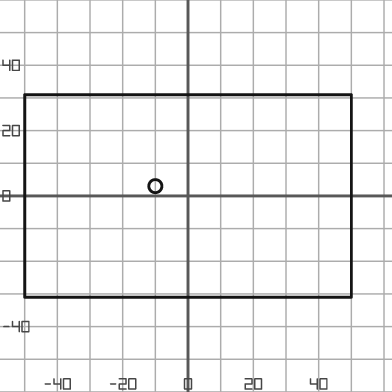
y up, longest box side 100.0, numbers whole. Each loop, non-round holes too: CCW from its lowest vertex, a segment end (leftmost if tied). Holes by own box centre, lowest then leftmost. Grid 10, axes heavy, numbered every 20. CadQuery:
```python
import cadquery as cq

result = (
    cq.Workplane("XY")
    .moveTo(-50.0, -31.0)
    .lineTo(50.0, -31.0)
    .lineTo(50.0, 31.0)
    .lineTo(-50.0, 31.0)
    .close()
    .moveTo(-10.0, 3.0)
    .circle(2.0)
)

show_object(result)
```